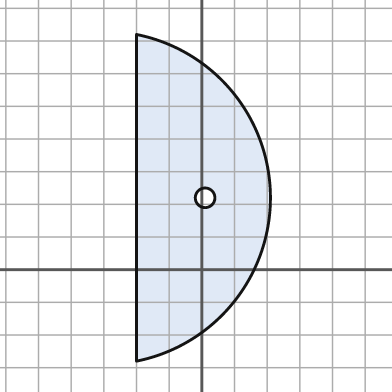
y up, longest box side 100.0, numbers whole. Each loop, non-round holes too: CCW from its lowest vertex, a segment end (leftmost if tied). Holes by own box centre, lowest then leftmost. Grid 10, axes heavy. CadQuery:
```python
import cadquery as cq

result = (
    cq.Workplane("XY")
    .moveTo(-20.0, -28.0)
    .threePointArc((21.0, 22.0), (-20.0, 72.0))
    .close()
    .moveTo(1.0, 22.0)
    .circle(3.0)
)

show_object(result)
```